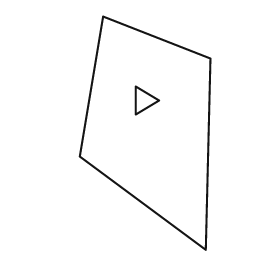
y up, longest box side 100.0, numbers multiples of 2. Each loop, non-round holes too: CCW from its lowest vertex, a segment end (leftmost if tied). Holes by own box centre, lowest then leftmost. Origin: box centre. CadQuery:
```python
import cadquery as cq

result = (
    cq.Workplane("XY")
    .moveTo(26.0, -50.0)
    .lineTo(28.0, 32.0)
    .lineTo(-18.0, 50.0)
    .lineTo(-28.0, -10.0)
    .close()
    .moveTo(-4.0, 8.0)
    .lineTo(6.0, 14.0)
    .lineTo(-4.0, 20.0)
    .close()
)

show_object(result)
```